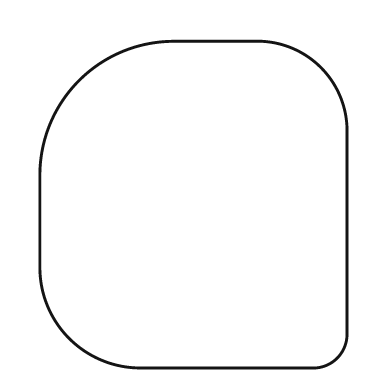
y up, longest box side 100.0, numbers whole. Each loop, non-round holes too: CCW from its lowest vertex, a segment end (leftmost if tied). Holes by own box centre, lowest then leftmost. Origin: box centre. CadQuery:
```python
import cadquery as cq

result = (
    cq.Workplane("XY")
    .moveTo(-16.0, -50.0)
    .lineTo(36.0, -50.0)
    .threePointArc((44.0, -47.0), (47.0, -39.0))
    .lineTo(47.0, 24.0)
    .threePointArc((39.0, 42.0), (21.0, 50.0))
    .lineTo(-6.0, 50.0)
    .threePointArc((-35.0, 38.0), (-47.0, 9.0))
    .lineTo(-47.0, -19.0)
    .threePointArc((-38.0, -41.0), (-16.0, -50.0))
    .close()
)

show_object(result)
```